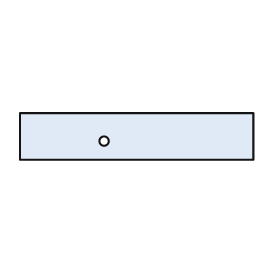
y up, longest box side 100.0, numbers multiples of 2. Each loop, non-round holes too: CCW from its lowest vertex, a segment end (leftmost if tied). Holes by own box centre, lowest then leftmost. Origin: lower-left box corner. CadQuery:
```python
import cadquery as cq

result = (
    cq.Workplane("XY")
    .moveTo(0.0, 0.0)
    .lineTo(100.0, 0.0)
    .lineTo(100.0, 20.0)
    .lineTo(0.0, 20.0)
    .close()
    .moveTo(36.0, 8.0)
    .circle(2.0)
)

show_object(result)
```